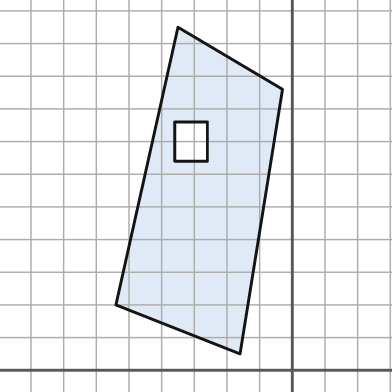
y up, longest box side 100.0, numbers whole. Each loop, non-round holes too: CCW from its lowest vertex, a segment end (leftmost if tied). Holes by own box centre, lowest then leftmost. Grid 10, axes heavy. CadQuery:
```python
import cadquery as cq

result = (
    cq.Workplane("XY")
    .moveTo(-16.0, 5.0)
    .lineTo(-3.0, 86.0)
    .lineTo(-35.0, 105.0)
    .lineTo(-54.0, 20.0)
    .close()
    .moveTo(-36.0, 64.0)
    .lineTo(-26.0, 64.0)
    .lineTo(-26.0, 76.0)
    .lineTo(-36.0, 76.0)
    .close()
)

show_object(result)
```